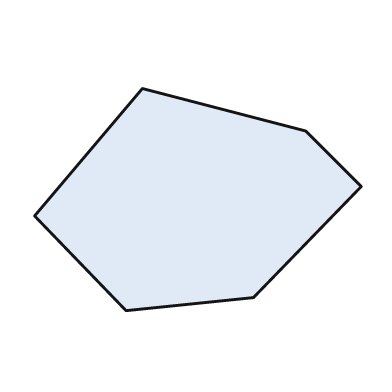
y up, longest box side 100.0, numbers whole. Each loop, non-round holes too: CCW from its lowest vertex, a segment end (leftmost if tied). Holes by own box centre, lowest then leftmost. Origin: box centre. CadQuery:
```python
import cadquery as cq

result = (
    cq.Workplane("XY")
    .moveTo(-22.0, -34.0)
    .lineTo(17.0, -30.0)
    .lineTo(50.0, 4.0)
    .lineTo(33.0, 21.0)
    .lineTo(-17.0, 34.0)
    .lineTo(-50.0, -5.0)
    .close()
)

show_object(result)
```